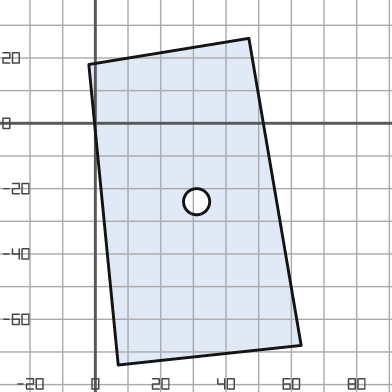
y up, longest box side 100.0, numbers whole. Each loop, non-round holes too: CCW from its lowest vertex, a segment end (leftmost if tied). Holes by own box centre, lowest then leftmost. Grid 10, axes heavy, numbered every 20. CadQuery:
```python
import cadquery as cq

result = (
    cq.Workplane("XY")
    .moveTo(7.0, -74.0)
    .lineTo(63.0, -68.0)
    .lineTo(47.0, 26.0)
    .lineTo(-2.0, 18.0)
    .close()
    .moveTo(31.0, -24.0)
    .circle(4.0)
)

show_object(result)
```